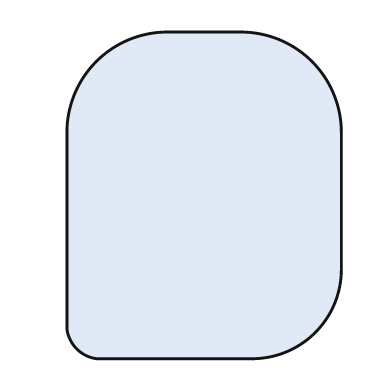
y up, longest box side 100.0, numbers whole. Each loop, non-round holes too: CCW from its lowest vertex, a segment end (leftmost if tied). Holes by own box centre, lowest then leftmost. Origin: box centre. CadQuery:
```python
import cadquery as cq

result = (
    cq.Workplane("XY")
    .moveTo(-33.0, -50.0)
    .lineTo(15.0, -50.0)
    .threePointArc((34.0, -42.0), (42.0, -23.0))
    .lineTo(42.0, 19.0)
    .threePointArc((33.0, 41.0), (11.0, 50.0))
    .lineTo(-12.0, 50.0)
    .threePointArc((-33.0, 41.0), (-42.0, 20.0))
    .lineTo(-42.0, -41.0)
    .threePointArc((-39.0, -47.0), (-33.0, -50.0))
    .close()
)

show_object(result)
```